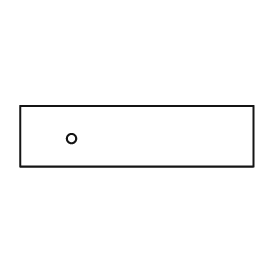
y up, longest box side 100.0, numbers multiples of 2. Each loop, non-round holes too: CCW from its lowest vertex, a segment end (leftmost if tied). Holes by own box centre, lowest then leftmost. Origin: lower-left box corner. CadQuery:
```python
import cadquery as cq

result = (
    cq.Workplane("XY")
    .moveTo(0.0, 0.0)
    .lineTo(100.0, 0.0)
    .lineTo(100.0, 26.0)
    .lineTo(0.0, 26.0)
    .close()
    .moveTo(22.0, 12.0)
    .circle(2.0)
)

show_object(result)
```